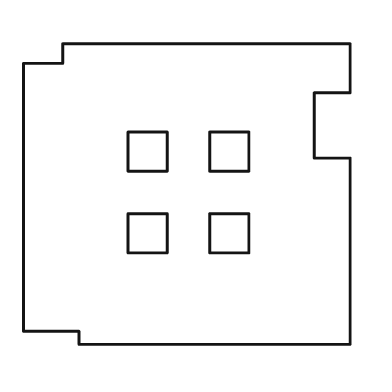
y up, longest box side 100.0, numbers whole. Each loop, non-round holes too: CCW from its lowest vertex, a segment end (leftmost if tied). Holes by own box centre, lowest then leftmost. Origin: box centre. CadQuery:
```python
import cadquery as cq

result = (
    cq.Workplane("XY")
    .moveTo(-33.0, -46.0)
    .lineTo(50.0, -46.0)
    .lineTo(50.0, 11.0)
    .lineTo(39.0, 11.0)
    .lineTo(39.0, 31.0)
    .lineTo(50.0, 31.0)
    .lineTo(50.0, 46.0)
    .lineTo(-38.0, 46.0)
    .lineTo(-38.0, 40.0)
    .lineTo(-50.0, 40.0)
    .lineTo(-50.0, -42.0)
    .lineTo(-33.0, -42.0)
    .close()
    .moveTo(-18.0, -18.0)
    .lineTo(-6.0, -18.0)
    .lineTo(-6.0, -6.0)
    .lineTo(-18.0, -6.0)
    .close()
    .moveTo(7.0, -18.0)
    .lineTo(19.0, -18.0)
    .lineTo(19.0, -6.0)
    .lineTo(7.0, -6.0)
    .close()
    .moveTo(-18.0, 7.0)
    .lineTo(-6.0, 7.0)
    .lineTo(-6.0, 19.0)
    .lineTo(-18.0, 19.0)
    .close()
    .moveTo(7.0, 7.0)
    .lineTo(19.0, 7.0)
    .lineTo(19.0, 19.0)
    .lineTo(7.0, 19.0)
    .close()
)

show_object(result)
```